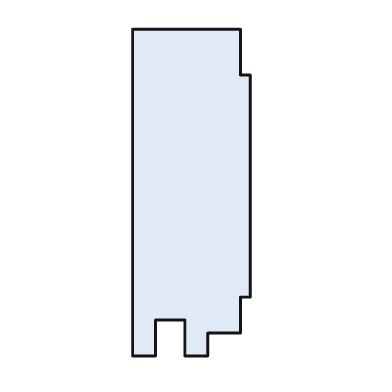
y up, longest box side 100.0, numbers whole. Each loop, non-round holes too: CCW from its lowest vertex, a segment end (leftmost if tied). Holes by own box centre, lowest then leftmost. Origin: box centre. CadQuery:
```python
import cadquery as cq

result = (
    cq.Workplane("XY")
    .moveTo(-18.0, -50.0)
    .lineTo(-11.0, -50.0)
    .lineTo(-11.0, -39.0)
    .lineTo(-2.0, -39.0)
    .lineTo(-2.0, -50.0)
    .lineTo(5.0, -50.0)
    .lineTo(5.0, -43.0)
    .lineTo(15.0, -43.0)
    .lineTo(15.0, -32.0)
    .lineTo(18.0, -32.0)
    .lineTo(18.0, 36.0)
    .lineTo(15.0, 36.0)
    .lineTo(15.0, 50.0)
    .lineTo(-18.0, 50.0)
    .close()
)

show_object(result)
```